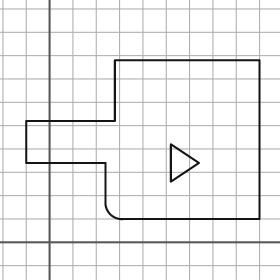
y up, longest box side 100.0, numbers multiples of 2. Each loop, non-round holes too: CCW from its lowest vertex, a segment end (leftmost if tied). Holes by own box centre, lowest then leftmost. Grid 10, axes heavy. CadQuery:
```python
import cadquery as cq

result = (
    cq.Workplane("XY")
    .moveTo(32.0, 10.0)
    .lineTo(90.0, 10.0)
    .lineTo(90.0, 78.0)
    .lineTo(28.0, 78.0)
    .lineTo(28.0, 52.0)
    .lineTo(-10.0, 52.0)
    .lineTo(-10.0, 34.0)
    .lineTo(24.0, 34.0)
    .lineTo(24.0, 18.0)
    .threePointArc((26.0, 12.0), (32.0, 10.0))
    .close()
    .moveTo(52.0, 26.0)
    .lineTo(64.0, 34.0)
    .lineTo(52.0, 42.0)
    .close()
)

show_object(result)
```